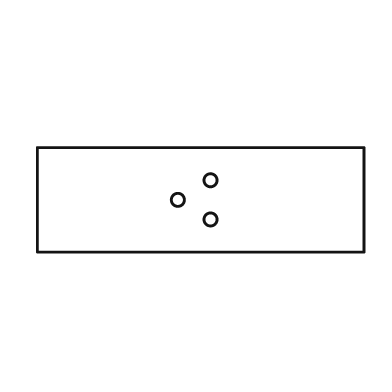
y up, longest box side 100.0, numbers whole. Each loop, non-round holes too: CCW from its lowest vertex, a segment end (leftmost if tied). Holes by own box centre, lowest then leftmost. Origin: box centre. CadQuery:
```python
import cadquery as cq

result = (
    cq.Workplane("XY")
    .moveTo(-50.0, -16.0)
    .lineTo(50.0, -16.0)
    .lineTo(50.0, 16.0)
    .lineTo(-50.0, 16.0)
    .close()
    .moveTo(3.0, -6.0)
    .circle(2.0)
    .moveTo(-7.0, 0.0)
    .circle(2.0)
    .moveTo(3.0, 6.0)
    .circle(2.0)
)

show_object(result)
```